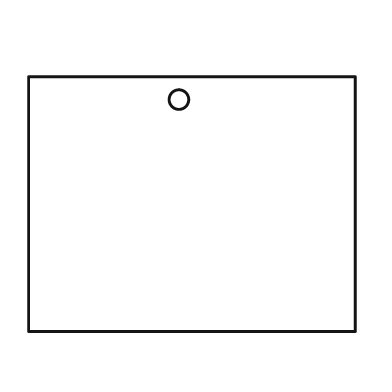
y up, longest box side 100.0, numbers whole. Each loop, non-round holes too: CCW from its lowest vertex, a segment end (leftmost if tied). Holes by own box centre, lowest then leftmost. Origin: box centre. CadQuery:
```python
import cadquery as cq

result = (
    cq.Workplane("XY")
    .moveTo(-50.0, -39.0)
    .lineTo(50.0, -39.0)
    .lineTo(50.0, 39.0)
    .lineTo(-50.0, 39.0)
    .close()
    .moveTo(-4.0, 32.0)
    .circle(3.0)
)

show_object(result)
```